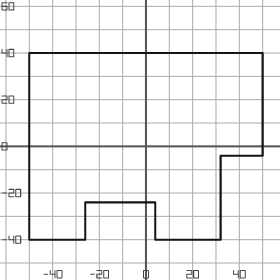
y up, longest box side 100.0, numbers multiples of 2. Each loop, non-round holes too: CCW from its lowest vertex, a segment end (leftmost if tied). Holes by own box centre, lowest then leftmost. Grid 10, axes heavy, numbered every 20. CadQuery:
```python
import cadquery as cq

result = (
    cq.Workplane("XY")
    .moveTo(-50.0, -40.0)
    .lineTo(-26.0, -40.0)
    .lineTo(-26.0, -24.0)
    .lineTo(4.0, -24.0)
    .lineTo(4.0, -40.0)
    .lineTo(32.0, -40.0)
    .lineTo(32.0, -4.0)
    .lineTo(50.0, -4.0)
    .lineTo(50.0, 40.0)
    .lineTo(-50.0, 40.0)
    .close()
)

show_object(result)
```